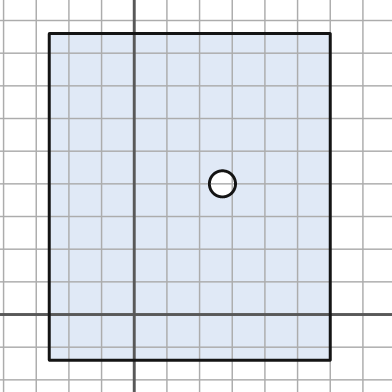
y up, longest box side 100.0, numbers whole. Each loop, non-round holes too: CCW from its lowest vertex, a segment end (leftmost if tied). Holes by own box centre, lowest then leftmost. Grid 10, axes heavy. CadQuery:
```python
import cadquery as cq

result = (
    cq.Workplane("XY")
    .moveTo(-26.0, -14.0)
    .lineTo(60.0, -14.0)
    .lineTo(60.0, 86.0)
    .lineTo(-26.0, 86.0)
    .close()
    .moveTo(27.0, 40.0)
    .circle(4.0)
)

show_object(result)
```